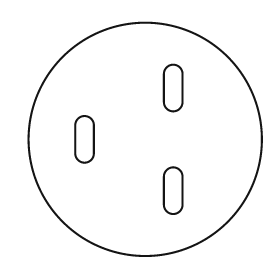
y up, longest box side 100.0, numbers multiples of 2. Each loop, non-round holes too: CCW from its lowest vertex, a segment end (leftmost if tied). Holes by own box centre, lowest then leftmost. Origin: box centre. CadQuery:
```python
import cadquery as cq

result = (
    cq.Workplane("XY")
    .moveTo(0.0, 0.0)
    .circle(50.0)
    .moveTo(8.0, -28.0)
    .threePointArc((12.0, -32.0), (16.0, -28.0))
    .lineTo(16.0, -16.0)
    .threePointArc((12.0, -12.0), (8.0, -16.0))
    .close()
    .moveTo(-30.0, -6.0)
    .threePointArc((-26.0, -10.0), (-22.0, -6.0))
    .lineTo(-22.0, 6.0)
    .threePointArc((-26.0, 10.0), (-30.0, 6.0))
    .close()
    .moveTo(8.0, 16.0)
    .threePointArc((12.0, 12.0), (16.0, 16.0))
    .lineTo(16.0, 28.0)
    .threePointArc((12.0, 32.0), (8.0, 28.0))
    .close()
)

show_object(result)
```